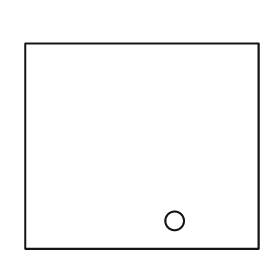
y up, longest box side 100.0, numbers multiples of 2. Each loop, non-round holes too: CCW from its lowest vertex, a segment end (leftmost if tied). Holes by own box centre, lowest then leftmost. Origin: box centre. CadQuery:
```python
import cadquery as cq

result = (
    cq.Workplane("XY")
    .moveTo(-50.0, -44.0)
    .lineTo(50.0, -44.0)
    .lineTo(50.0, 44.0)
    .lineTo(-50.0, 44.0)
    .close()
    .moveTo(14.0, -32.0)
    .circle(4.0)
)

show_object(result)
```